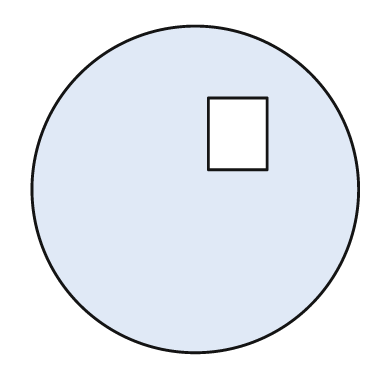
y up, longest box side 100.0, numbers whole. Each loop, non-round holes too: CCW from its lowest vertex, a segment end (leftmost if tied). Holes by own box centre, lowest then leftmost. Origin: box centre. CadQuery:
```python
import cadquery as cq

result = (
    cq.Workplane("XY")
    .moveTo(0.0, 0.0)
    .circle(50.0)
    .moveTo(4.0, 6.0)
    .lineTo(22.0, 6.0)
    .lineTo(22.0, 28.0)
    .lineTo(4.0, 28.0)
    .close()
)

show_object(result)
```